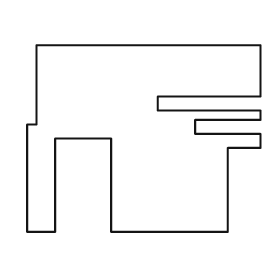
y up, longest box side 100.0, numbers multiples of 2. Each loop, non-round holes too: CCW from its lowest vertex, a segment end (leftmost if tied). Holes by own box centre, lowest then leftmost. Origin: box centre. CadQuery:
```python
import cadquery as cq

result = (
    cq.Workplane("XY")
    .moveTo(-50.0, -40.0)
    .lineTo(-38.0, -40.0)
    .lineTo(-38.0, 0.0)
    .lineTo(-14.0, 0.0)
    .lineTo(-14.0, -40.0)
    .lineTo(36.0, -40.0)
    .lineTo(36.0, -4.0)
    .lineTo(50.0, -4.0)
    .lineTo(50.0, 2.0)
    .lineTo(22.0, 2.0)
    .lineTo(22.0, 8.0)
    .lineTo(50.0, 8.0)
    .lineTo(50.0, 12.0)
    .lineTo(6.0, 12.0)
    .lineTo(6.0, 18.0)
    .lineTo(50.0, 18.0)
    .lineTo(50.0, 40.0)
    .lineTo(-46.0, 40.0)
    .lineTo(-46.0, 6.0)
    .lineTo(-50.0, 6.0)
    .close()
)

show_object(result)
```